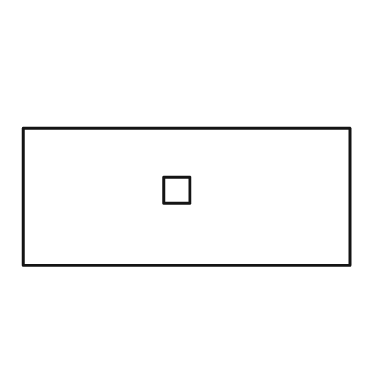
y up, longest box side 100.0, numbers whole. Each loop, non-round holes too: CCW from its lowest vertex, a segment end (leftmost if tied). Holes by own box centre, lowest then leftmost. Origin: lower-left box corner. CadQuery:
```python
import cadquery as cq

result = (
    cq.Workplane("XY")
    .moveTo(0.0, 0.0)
    .lineTo(100.0, 0.0)
    .lineTo(100.0, 42.0)
    .lineTo(0.0, 42.0)
    .close()
    .moveTo(43.0, 19.0)
    .lineTo(51.0, 19.0)
    .lineTo(51.0, 27.0)
    .lineTo(43.0, 27.0)
    .close()
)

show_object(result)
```